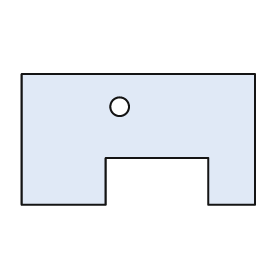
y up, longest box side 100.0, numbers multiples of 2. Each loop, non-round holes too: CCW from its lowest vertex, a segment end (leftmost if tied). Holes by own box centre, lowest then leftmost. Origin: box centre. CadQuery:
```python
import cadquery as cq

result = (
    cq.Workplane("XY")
    .moveTo(-50.0, -28.0)
    .lineTo(-14.0, -28.0)
    .lineTo(-14.0, -8.0)
    .lineTo(30.0, -8.0)
    .lineTo(30.0, -28.0)
    .lineTo(50.0, -28.0)
    .lineTo(50.0, 28.0)
    .lineTo(-50.0, 28.0)
    .close()
    .moveTo(-8.0, 14.0)
    .circle(4.0)
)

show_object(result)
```